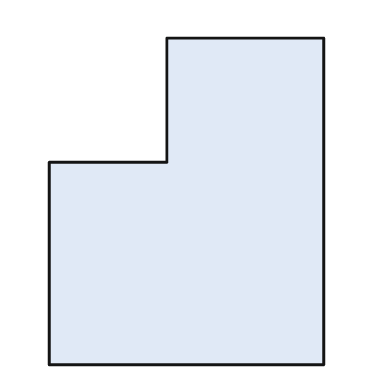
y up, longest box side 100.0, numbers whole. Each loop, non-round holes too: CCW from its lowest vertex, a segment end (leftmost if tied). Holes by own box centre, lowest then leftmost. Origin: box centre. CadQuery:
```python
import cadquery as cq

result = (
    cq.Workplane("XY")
    .moveTo(-42.0, -50.0)
    .lineTo(42.0, -50.0)
    .lineTo(42.0, 50.0)
    .lineTo(-6.0, 50.0)
    .lineTo(-6.0, 12.0)
    .lineTo(-42.0, 12.0)
    .close()
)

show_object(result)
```